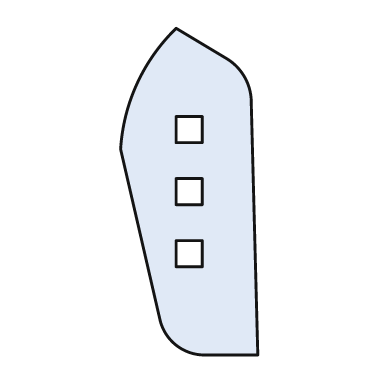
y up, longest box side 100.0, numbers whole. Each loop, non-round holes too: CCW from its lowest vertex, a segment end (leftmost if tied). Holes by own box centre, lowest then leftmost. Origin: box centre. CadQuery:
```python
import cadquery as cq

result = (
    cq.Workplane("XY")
    .moveTo(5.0, -50.0)
    .lineTo(21.0, -50.0)
    .lineTo(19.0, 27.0)
    .threePointArc((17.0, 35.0), (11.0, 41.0))
    .lineTo(-4.0, 50.0)
    .threePointArc((-16.0, 33.0), (-21.0, 13.0))
    .lineTo(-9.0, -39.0)
    .threePointArc((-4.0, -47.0), (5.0, -50.0))
    .close()
    .moveTo(-4.0, -23.0)
    .lineTo(4.0, -23.0)
    .lineTo(4.0, -15.0)
    .lineTo(-4.0, -15.0)
    .close()
    .moveTo(-4.0, -4.0)
    .lineTo(4.0, -4.0)
    .lineTo(4.0, 4.0)
    .lineTo(-4.0, 4.0)
    .close()
    .moveTo(-4.0, 15.0)
    .lineTo(4.0, 15.0)
    .lineTo(4.0, 23.0)
    .lineTo(-4.0, 23.0)
    .close()
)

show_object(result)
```